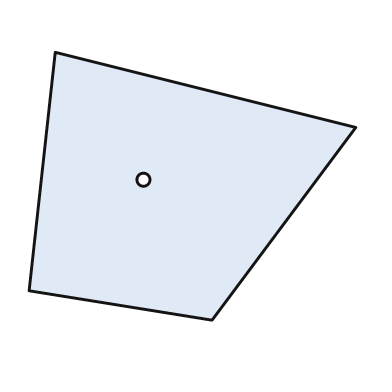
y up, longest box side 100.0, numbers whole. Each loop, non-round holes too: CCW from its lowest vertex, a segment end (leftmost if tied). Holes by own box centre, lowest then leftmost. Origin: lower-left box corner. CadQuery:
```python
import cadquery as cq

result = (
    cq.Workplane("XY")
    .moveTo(56.0, 0.0)
    .lineTo(100.0, 59.0)
    .lineTo(8.0, 82.0)
    .lineTo(0.0, 9.0)
    .close()
    .moveTo(35.0, 43.0)
    .circle(2.0)
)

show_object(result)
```